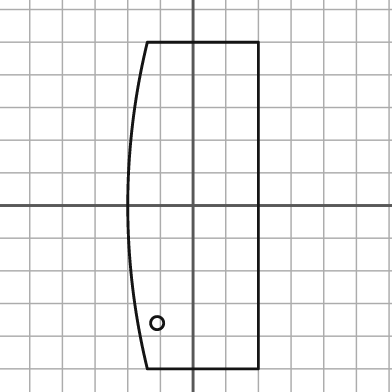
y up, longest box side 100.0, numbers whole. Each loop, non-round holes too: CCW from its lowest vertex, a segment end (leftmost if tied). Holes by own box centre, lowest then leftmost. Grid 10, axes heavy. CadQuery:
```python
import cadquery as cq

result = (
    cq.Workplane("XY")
    .moveTo(-14.0, -50.0)
    .lineTo(20.0, -50.0)
    .lineTo(20.0, 50.0)
    .lineTo(-14.0, 50.0)
    .threePointArc((-20.0, 0.0), (-14.0, -50.0))
    .close()
    .moveTo(-11.0, -36.0)
    .circle(2.0)
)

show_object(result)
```